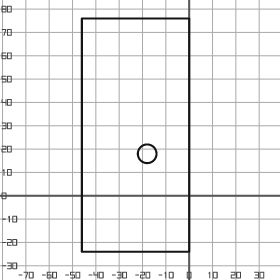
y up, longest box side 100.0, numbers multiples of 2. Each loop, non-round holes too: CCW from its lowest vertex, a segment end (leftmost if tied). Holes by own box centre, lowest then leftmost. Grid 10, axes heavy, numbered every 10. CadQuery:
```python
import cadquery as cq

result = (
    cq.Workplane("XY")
    .moveTo(-46.0, -24.0)
    .lineTo(0.0, -24.0)
    .lineTo(0.0, 76.0)
    .lineTo(-46.0, 76.0)
    .close()
    .moveTo(-18.0, 18.0)
    .circle(4.0)
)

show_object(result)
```